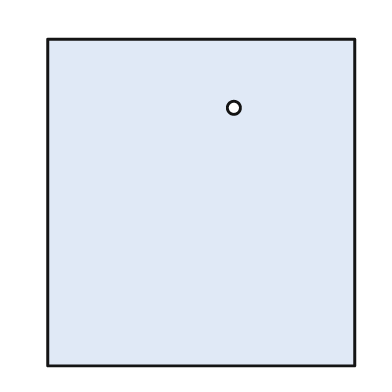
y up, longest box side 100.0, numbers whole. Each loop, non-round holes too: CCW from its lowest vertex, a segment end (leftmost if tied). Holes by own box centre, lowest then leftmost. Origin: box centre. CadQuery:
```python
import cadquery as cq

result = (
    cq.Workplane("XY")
    .moveTo(-47.0, -50.0)
    .lineTo(47.0, -50.0)
    .lineTo(47.0, 50.0)
    .lineTo(-47.0, 50.0)
    .close()
    .moveTo(10.0, 29.0)
    .circle(2.0)
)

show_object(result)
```